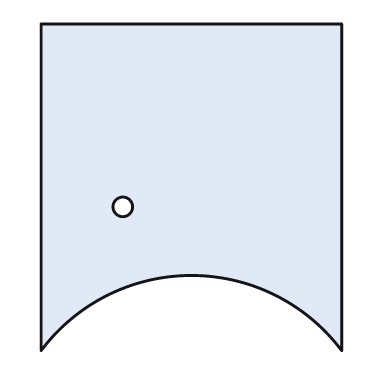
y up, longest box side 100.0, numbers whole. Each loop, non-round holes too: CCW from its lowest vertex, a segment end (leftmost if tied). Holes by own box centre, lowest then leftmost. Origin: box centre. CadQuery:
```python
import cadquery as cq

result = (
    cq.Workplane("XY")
    .moveTo(-46.0, -50.0)
    .threePointArc((0.0, -27.0), (46.0, -50.0))
    .lineTo(46.0, 50.0)
    .lineTo(-46.0, 50.0)
    .close()
    .moveTo(-21.0, -6.0)
    .circle(3.0)
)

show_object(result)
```